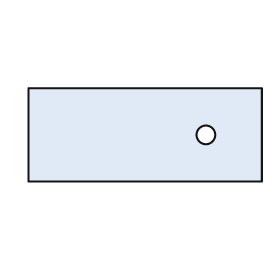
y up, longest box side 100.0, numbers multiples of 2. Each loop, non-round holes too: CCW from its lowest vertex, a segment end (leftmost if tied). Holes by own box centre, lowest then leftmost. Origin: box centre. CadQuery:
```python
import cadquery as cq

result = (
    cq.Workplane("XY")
    .moveTo(-50.0, -20.0)
    .lineTo(50.0, -20.0)
    .lineTo(50.0, 20.0)
    .lineTo(-50.0, 20.0)
    .close()
    .moveTo(26.0, 0.0)
    .circle(4.0)
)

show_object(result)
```